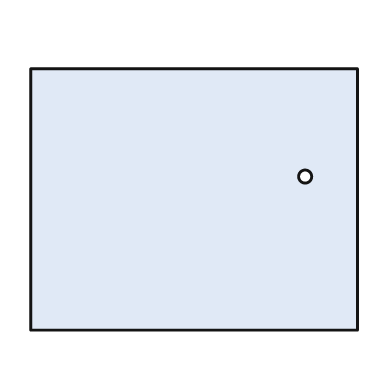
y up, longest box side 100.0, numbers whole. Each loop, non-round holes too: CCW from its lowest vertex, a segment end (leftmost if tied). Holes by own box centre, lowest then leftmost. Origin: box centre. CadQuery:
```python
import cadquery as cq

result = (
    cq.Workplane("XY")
    .moveTo(-50.0, -40.0)
    .lineTo(50.0, -40.0)
    .lineTo(50.0, 40.0)
    .lineTo(-50.0, 40.0)
    .close()
    .moveTo(34.0, 7.0)
    .circle(2.0)
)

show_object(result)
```